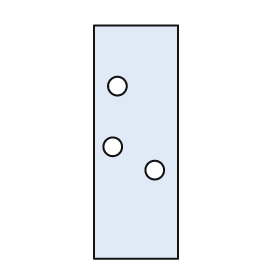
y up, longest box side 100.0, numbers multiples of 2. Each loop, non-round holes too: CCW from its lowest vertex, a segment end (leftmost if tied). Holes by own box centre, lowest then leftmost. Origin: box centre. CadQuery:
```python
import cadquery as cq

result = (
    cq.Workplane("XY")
    .moveTo(-18.0, -50.0)
    .lineTo(18.0, -50.0)
    .lineTo(18.0, 50.0)
    .lineTo(-18.0, 50.0)
    .close()
    .moveTo(8.0, -12.0)
    .circle(4.0)
    .moveTo(-10.0, -2.0)
    .circle(4.0)
    .moveTo(-8.0, 24.0)
    .circle(4.0)
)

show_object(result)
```